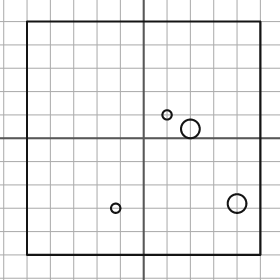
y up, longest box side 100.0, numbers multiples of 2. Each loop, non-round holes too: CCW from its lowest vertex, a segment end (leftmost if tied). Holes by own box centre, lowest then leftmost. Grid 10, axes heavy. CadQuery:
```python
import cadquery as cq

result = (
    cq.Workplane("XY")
    .moveTo(-50.0, -50.0)
    .lineTo(50.0, -50.0)
    .lineTo(50.0, 50.0)
    .lineTo(-50.0, 50.0)
    .close()
    .moveTo(-12.0, -30.0)
    .circle(2.0)
    .moveTo(40.0, -28.0)
    .circle(4.0)
    .moveTo(20.0, 4.0)
    .circle(4.0)
    .moveTo(10.0, 10.0)
    .circle(2.0)
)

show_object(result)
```